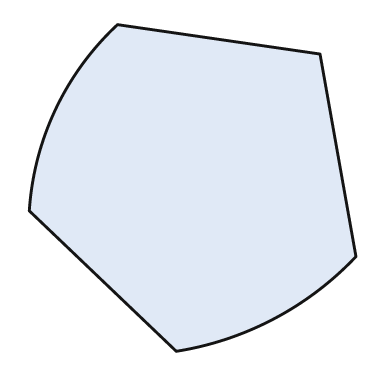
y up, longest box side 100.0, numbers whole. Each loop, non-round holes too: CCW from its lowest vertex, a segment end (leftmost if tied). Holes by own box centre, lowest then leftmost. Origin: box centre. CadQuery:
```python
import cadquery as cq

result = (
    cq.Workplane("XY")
    .moveTo(-5.0, -50.0)
    .threePointArc((25.0, -40.0), (50.0, -21.0))
    .lineTo(39.0, 41.0)
    .lineTo(-23.0, 50.0)
    .threePointArc((-42.0, 24.0), (-50.0, -7.0))
    .close()
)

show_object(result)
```